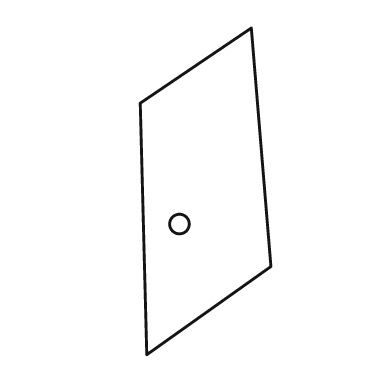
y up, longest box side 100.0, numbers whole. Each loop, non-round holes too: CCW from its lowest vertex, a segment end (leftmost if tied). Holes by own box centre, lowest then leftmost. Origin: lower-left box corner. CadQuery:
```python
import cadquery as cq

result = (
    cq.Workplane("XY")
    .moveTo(2.0, 0.0)
    .lineTo(40.0, 27.0)
    .lineTo(34.0, 100.0)
    .lineTo(0.0, 77.0)
    .close()
    .moveTo(12.0, 40.0)
    .circle(3.0)
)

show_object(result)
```